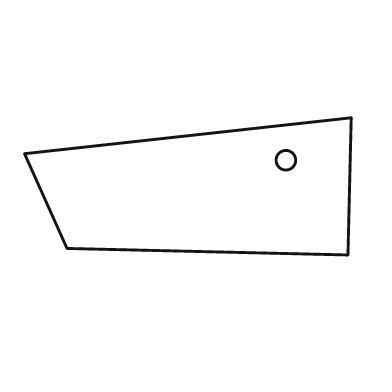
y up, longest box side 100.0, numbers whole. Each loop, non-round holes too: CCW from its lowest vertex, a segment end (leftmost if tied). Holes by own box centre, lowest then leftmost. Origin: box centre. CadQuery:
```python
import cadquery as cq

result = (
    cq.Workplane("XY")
    .moveTo(49.0, -21.0)
    .lineTo(50.0, 21.0)
    .lineTo(-50.0, 10.0)
    .lineTo(-37.0, -19.0)
    .close()
    .moveTo(30.0, 8.0)
    .circle(3.0)
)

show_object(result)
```